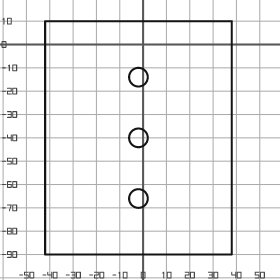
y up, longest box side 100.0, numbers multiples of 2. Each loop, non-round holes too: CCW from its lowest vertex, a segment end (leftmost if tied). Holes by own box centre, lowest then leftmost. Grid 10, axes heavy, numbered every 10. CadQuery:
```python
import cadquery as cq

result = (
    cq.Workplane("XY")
    .moveTo(-42.0, -90.0)
    .lineTo(38.0, -90.0)
    .lineTo(38.0, 10.0)
    .lineTo(-42.0, 10.0)
    .close()
    .moveTo(-2.0, -66.0)
    .circle(4.0)
    .moveTo(-2.0, -40.0)
    .circle(4.0)
    .moveTo(-2.0, -14.0)
    .circle(4.0)
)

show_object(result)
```